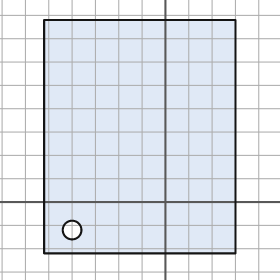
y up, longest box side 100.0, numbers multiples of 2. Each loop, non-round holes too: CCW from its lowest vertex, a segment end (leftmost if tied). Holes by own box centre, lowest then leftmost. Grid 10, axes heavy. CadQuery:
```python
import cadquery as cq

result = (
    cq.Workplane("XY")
    .moveTo(-52.0, -22.0)
    .lineTo(30.0, -22.0)
    .lineTo(30.0, 78.0)
    .lineTo(-52.0, 78.0)
    .close()
    .moveTo(-40.0, -12.0)
    .circle(4.0)
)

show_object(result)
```